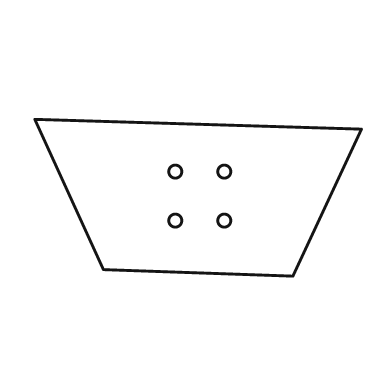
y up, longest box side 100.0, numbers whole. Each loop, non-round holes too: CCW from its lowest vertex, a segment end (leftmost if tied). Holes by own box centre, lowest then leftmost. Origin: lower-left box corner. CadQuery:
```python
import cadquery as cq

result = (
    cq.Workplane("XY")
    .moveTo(79.0, 0.0)
    .lineTo(100.0, 45.0)
    .lineTo(0.0, 48.0)
    .lineTo(21.0, 2.0)
    .close()
    .moveTo(43.0, 17.0)
    .circle(2.0)
    .moveTo(58.0, 17.0)
    .circle(2.0)
    .moveTo(43.0, 32.0)
    .circle(2.0)
    .moveTo(58.0, 32.0)
    .circle(2.0)
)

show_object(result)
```